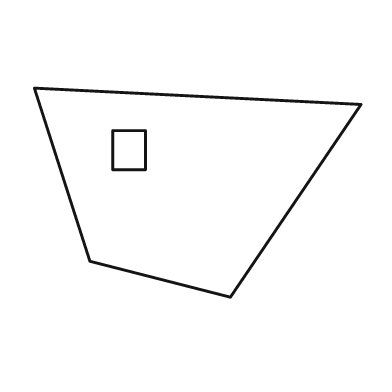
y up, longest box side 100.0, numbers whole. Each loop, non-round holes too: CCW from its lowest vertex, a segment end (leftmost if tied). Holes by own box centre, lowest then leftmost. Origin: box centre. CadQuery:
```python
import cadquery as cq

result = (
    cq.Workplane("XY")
    .moveTo(10.0, -32.0)
    .lineTo(50.0, 27.0)
    .lineTo(-50.0, 32.0)
    .lineTo(-33.0, -21.0)
    .close()
    .moveTo(-26.0, 7.0)
    .lineTo(-16.0, 7.0)
    .lineTo(-16.0, 19.0)
    .lineTo(-26.0, 19.0)
    .close()
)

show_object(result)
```